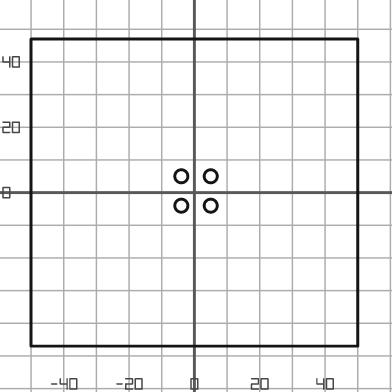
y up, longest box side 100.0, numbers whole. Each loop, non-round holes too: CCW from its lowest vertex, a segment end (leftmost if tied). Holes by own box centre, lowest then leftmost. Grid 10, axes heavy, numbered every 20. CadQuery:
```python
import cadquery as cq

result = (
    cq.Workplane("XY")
    .moveTo(-50.0, -47.0)
    .lineTo(50.0, -47.0)
    .lineTo(50.0, 47.0)
    .lineTo(-50.0, 47.0)
    .close()
    .moveTo(-4.0, -4.0)
    .circle(2.0)
    .moveTo(5.0, -4.0)
    .circle(2.0)
    .moveTo(-4.0, 5.0)
    .circle(2.0)
    .moveTo(5.0, 5.0)
    .circle(2.0)
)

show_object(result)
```